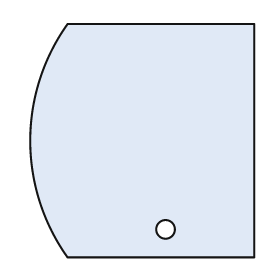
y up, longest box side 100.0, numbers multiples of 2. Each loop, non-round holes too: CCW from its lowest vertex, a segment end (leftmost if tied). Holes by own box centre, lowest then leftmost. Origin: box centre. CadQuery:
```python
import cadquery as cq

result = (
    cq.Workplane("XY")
    .moveTo(-32.0, -50.0)
    .lineTo(48.0, -50.0)
    .lineTo(48.0, 50.0)
    .lineTo(-32.0, 50.0)
    .threePointArc((-48.0, 0.0), (-32.0, -50.0))
    .close()
    .moveTo(10.0, -38.0)
    .circle(4.0)
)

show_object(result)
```